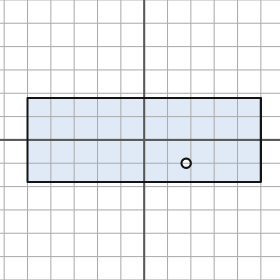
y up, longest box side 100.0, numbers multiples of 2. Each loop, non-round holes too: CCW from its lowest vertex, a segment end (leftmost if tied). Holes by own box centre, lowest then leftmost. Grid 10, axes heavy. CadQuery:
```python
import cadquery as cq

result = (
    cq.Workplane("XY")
    .moveTo(-50.0, -18.0)
    .lineTo(50.0, -18.0)
    .lineTo(50.0, 18.0)
    .lineTo(-50.0, 18.0)
    .close()
    .moveTo(18.0, -10.0)
    .circle(2.0)
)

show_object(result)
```